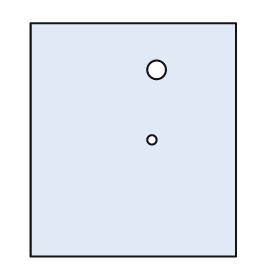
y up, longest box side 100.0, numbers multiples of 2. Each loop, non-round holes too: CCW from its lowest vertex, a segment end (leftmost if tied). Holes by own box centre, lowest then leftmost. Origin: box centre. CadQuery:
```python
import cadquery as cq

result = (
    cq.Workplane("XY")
    .moveTo(-44.0, -50.0)
    .lineTo(44.0, -50.0)
    .lineTo(44.0, 50.0)
    .lineTo(-44.0, 50.0)
    .close()
    .moveTo(8.0, 0.0)
    .circle(2.0)
    .moveTo(10.0, 30.0)
    .circle(4.0)
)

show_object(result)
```